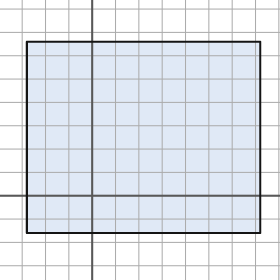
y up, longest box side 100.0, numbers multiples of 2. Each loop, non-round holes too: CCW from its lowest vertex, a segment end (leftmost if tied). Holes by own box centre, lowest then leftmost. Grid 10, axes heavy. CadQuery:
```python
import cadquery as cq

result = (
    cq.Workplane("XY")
    .moveTo(-28.0, -16.0)
    .lineTo(72.0, -16.0)
    .lineTo(72.0, 66.0)
    .lineTo(-28.0, 66.0)
    .close()
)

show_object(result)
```